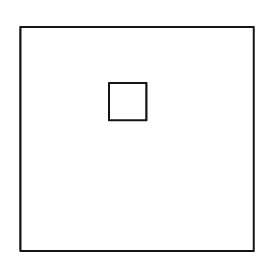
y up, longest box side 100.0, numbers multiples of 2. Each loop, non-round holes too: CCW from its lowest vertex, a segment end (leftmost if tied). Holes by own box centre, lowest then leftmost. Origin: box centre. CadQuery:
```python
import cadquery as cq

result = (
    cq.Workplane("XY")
    .moveTo(-50.0, -48.0)
    .lineTo(50.0, -48.0)
    .lineTo(50.0, 48.0)
    .lineTo(-50.0, 48.0)
    .close()
    .moveTo(-12.0, 8.0)
    .lineTo(4.0, 8.0)
    .lineTo(4.0, 24.0)
    .lineTo(-12.0, 24.0)
    .close()
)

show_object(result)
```